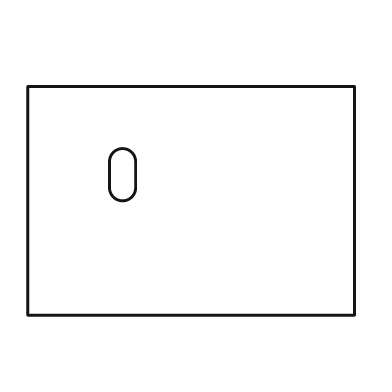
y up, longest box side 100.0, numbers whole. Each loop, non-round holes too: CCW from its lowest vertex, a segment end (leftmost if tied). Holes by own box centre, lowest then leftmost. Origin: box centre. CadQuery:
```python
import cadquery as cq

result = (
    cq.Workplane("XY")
    .moveTo(-50.0, -35.0)
    .lineTo(50.0, -35.0)
    .lineTo(50.0, 35.0)
    .lineTo(-50.0, 35.0)
    .close()
    .moveTo(-25.0, 4.0)
    .threePointArc((-21.0, 0.0), (-17.0, 4.0))
    .lineTo(-17.0, 12.0)
    .threePointArc((-21.0, 16.0), (-25.0, 12.0))
    .close()
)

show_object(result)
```